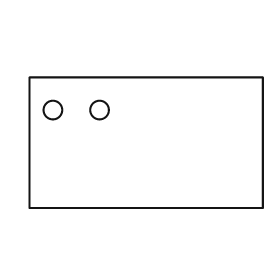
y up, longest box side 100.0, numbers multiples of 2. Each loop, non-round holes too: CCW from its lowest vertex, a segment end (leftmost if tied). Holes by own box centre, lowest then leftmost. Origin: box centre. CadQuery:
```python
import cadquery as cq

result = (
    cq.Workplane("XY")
    .moveTo(-50.0, -28.0)
    .lineTo(50.0, -28.0)
    .lineTo(50.0, 28.0)
    .lineTo(-50.0, 28.0)
    .close()
    .moveTo(-40.0, 14.0)
    .circle(4.0)
    .moveTo(-20.0, 14.0)
    .circle(4.0)
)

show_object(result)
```